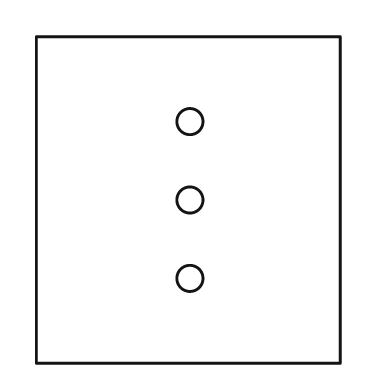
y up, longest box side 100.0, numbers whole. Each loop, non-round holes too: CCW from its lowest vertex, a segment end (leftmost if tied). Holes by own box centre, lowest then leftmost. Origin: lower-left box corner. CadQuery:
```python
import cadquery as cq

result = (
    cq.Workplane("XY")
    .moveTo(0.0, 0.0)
    .lineTo(93.0, 0.0)
    .lineTo(93.0, 100.0)
    .lineTo(0.0, 100.0)
    .close()
    .moveTo(47.0, 26.0)
    .circle(4.0)
    .moveTo(47.0, 50.0)
    .circle(4.0)
    .moveTo(47.0, 74.0)
    .circle(4.0)
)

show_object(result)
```